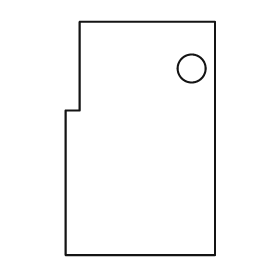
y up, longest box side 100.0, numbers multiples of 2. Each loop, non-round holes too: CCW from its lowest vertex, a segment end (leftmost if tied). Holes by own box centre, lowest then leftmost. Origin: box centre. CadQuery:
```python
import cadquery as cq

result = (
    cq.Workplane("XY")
    .moveTo(-32.0, -50.0)
    .lineTo(32.0, -50.0)
    .lineTo(32.0, 50.0)
    .lineTo(-26.0, 50.0)
    .lineTo(-26.0, 12.0)
    .lineTo(-32.0, 12.0)
    .close()
    .moveTo(22.0, 30.0)
    .circle(6.0)
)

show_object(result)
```